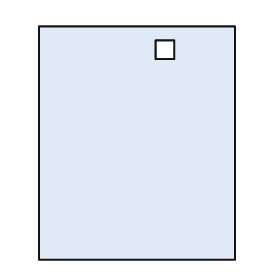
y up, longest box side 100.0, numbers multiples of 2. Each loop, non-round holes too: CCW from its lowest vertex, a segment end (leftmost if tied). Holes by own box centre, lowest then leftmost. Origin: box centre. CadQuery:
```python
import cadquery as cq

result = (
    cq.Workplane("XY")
    .moveTo(-42.0, -50.0)
    .lineTo(42.0, -50.0)
    .lineTo(42.0, 50.0)
    .lineTo(-42.0, 50.0)
    .close()
    .moveTo(8.0, 36.0)
    .lineTo(16.0, 36.0)
    .lineTo(16.0, 44.0)
    .lineTo(8.0, 44.0)
    .close()
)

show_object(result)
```